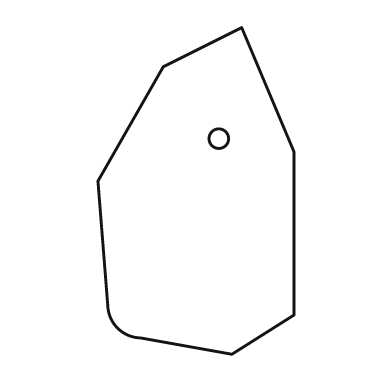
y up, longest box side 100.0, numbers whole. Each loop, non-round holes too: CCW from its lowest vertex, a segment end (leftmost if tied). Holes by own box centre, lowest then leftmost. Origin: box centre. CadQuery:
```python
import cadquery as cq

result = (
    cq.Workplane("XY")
    .moveTo(11.0, -50.0)
    .lineTo(30.0, -38.0)
    .lineTo(30.0, 12.0)
    .lineTo(14.0, 50.0)
    .lineTo(-10.0, 38.0)
    .lineTo(-30.0, 3.0)
    .lineTo(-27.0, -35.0)
    .threePointArc((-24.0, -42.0), (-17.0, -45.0))
    .close()
    .moveTo(7.0, 16.0)
    .circle(3.0)
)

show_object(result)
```